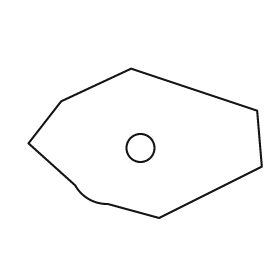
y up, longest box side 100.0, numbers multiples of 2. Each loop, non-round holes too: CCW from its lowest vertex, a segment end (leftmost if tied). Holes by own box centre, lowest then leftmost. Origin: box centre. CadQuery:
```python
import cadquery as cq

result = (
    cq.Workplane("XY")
    .moveTo(6.0, -32.0)
    .lineTo(50.0, -10.0)
    .lineTo(48.0, 14.0)
    .lineTo(-6.0, 32.0)
    .lineTo(-36.0, 18.0)
    .lineTo(-50.0, 0.0)
    .lineTo(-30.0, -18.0)
    .threePointArc((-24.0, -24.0), (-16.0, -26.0))
    .close()
    .moveTo(-2.0, -2.0)
    .circle(6.0)
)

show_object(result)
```